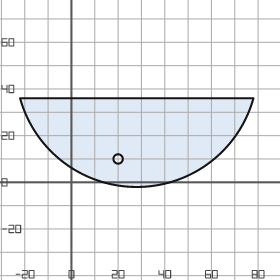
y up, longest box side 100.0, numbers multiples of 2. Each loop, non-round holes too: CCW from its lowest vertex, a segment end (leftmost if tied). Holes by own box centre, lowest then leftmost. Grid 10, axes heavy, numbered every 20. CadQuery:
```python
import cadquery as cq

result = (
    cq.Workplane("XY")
    .moveTo(-22.0, 36.0)
    .threePointArc((28.0, -2.0), (78.0, 36.0))
    .close()
    .moveTo(20.0, 10.0)
    .circle(2.0)
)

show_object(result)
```